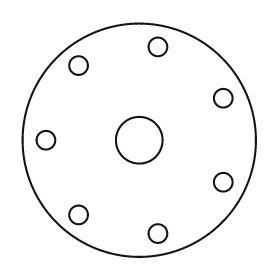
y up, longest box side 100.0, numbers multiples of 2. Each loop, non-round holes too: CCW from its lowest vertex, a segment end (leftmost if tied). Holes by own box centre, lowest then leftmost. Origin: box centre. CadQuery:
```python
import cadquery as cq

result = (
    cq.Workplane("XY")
    .moveTo(0.0, 0.0)
    .circle(50.0)
    .moveTo(8.0, -40.0)
    .circle(4.0)
    .moveTo(-26.0, -32.0)
    .circle(4.0)
    .moveTo(36.0, -18.0)
    .circle(4.0)
    .moveTo(-40.0, 0.0)
    .circle(4.0)
    .moveTo(0.0, 0.0)
    .circle(10.0)
    .moveTo(36.0, 18.0)
    .circle(4.0)
    .moveTo(-26.0, 32.0)
    .circle(4.0)
    .moveTo(8.0, 40.0)
    .circle(4.0)
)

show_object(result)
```